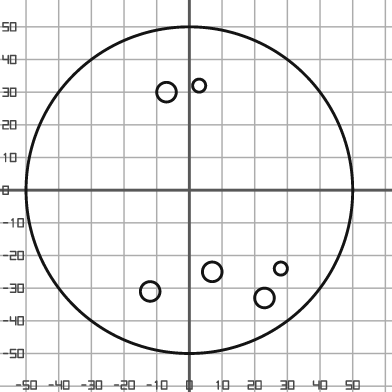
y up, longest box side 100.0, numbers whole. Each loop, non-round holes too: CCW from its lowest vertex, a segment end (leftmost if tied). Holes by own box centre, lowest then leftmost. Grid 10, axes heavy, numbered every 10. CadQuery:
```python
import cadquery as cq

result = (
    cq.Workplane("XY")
    .moveTo(0.0, 0.0)
    .circle(50.0)
    .moveTo(23.0, -33.0)
    .circle(3.0)
    .moveTo(-12.0, -31.0)
    .circle(3.0)
    .moveTo(7.0, -25.0)
    .circle(3.0)
    .moveTo(28.0, -24.0)
    .circle(2.0)
    .moveTo(-7.0, 30.0)
    .circle(3.0)
    .moveTo(3.0, 32.0)
    .circle(2.0)
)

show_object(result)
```